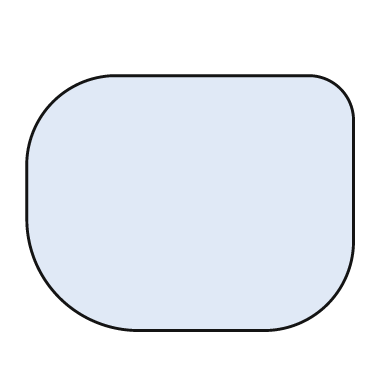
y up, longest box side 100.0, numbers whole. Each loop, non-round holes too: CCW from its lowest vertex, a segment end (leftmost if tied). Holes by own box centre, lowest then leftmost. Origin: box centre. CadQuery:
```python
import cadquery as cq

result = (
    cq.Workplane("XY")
    .moveTo(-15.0, -39.0)
    .lineTo(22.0, -39.0)
    .threePointArc((42.0, -31.0), (50.0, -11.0))
    .lineTo(50.0, 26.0)
    .threePointArc((46.0, 35.0), (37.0, 39.0))
    .lineTo(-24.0, 39.0)
    .threePointArc((-42.0, 31.0), (-50.0, 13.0))
    .lineTo(-50.0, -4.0)
    .threePointArc((-40.0, -29.0), (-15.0, -39.0))
    .close()
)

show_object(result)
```